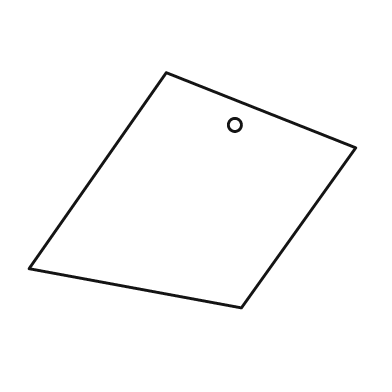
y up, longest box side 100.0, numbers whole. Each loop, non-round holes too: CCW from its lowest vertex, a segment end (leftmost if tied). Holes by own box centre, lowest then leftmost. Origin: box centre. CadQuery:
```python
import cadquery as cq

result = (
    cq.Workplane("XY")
    .moveTo(15.0, -36.0)
    .lineTo(50.0, 13.0)
    .lineTo(-8.0, 36.0)
    .lineTo(-50.0, -24.0)
    .close()
    .moveTo(13.0, 20.0)
    .circle(2.0)
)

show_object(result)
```